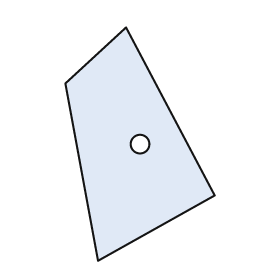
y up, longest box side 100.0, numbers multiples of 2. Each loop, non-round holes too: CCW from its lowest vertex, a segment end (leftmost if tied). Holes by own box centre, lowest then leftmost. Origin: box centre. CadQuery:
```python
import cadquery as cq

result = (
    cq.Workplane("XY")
    .moveTo(-18.0, -50.0)
    .lineTo(32.0, -22.0)
    .lineTo(-6.0, 50.0)
    .lineTo(-32.0, 26.0)
    .close()
    .moveTo(0.0, 0.0)
    .circle(4.0)
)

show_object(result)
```